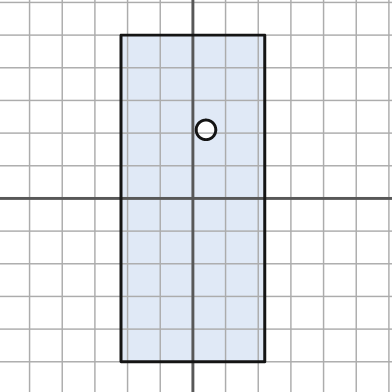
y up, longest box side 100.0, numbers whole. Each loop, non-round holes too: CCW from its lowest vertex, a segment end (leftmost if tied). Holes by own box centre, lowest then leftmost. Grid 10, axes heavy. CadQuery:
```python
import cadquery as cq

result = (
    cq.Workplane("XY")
    .moveTo(-22.0, -50.0)
    .lineTo(22.0, -50.0)
    .lineTo(22.0, 50.0)
    .lineTo(-22.0, 50.0)
    .close()
    .moveTo(4.0, 21.0)
    .circle(3.0)
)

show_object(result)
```